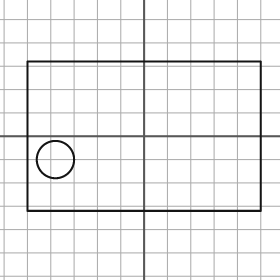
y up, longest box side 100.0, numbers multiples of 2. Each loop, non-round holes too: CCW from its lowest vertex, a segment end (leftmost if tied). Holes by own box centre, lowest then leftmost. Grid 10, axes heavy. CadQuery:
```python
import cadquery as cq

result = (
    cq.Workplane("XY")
    .moveTo(-50.0, -32.0)
    .lineTo(50.0, -32.0)
    .lineTo(50.0, 32.0)
    .lineTo(-50.0, 32.0)
    .close()
    .moveTo(-38.0, -10.0)
    .circle(8.0)
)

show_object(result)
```